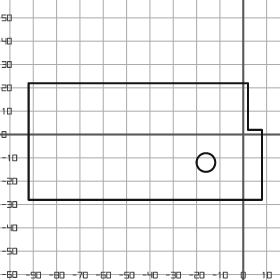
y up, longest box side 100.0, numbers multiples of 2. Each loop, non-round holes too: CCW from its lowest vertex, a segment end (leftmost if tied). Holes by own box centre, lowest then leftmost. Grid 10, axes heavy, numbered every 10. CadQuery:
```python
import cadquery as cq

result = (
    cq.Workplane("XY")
    .moveTo(-92.0, -28.0)
    .lineTo(8.0, -28.0)
    .lineTo(8.0, 2.0)
    .lineTo(2.0, 2.0)
    .lineTo(2.0, 22.0)
    .lineTo(-92.0, 22.0)
    .close()
    .moveTo(-16.0, -12.0)
    .circle(4.0)
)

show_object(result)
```